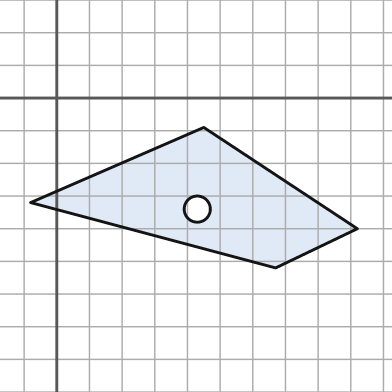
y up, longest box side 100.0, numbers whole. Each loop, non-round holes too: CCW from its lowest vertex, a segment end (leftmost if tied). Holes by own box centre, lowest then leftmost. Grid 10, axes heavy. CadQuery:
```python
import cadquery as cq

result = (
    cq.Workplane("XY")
    .moveTo(67.0, -52.0)
    .lineTo(92.0, -40.0)
    .lineTo(45.0, -9.0)
    .lineTo(-8.0, -32.0)
    .close()
    .moveTo(43.0, -34.0)
    .circle(4.0)
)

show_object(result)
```